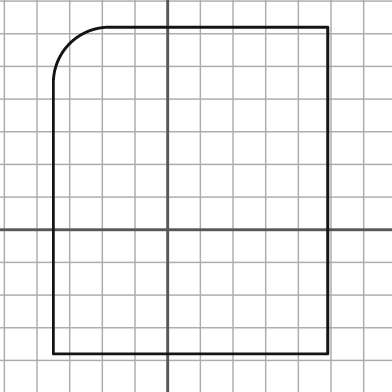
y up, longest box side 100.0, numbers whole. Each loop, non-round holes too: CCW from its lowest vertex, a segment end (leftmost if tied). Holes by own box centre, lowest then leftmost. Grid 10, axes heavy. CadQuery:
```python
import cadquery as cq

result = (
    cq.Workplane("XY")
    .moveTo(-35.0, -38.0)
    .lineTo(49.0, -38.0)
    .lineTo(49.0, 62.0)
    .lineTo(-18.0, 62.0)
    .threePointArc((-30.0, 57.0), (-35.0, 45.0))
    .close()
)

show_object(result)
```